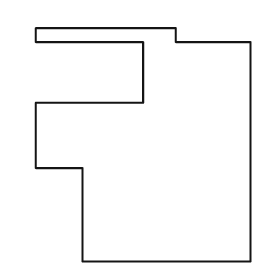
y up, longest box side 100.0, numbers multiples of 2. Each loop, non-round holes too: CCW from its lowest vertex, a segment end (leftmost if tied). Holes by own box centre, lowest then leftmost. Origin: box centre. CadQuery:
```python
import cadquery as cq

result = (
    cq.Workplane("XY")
    .moveTo(-26.0, -50.0)
    .lineTo(46.0, -50.0)
    .lineTo(46.0, 44.0)
    .lineTo(14.0, 44.0)
    .lineTo(14.0, 50.0)
    .lineTo(-46.0, 50.0)
    .lineTo(-46.0, 44.0)
    .lineTo(0.0, 44.0)
    .lineTo(0.0, 18.0)
    .lineTo(-46.0, 18.0)
    .lineTo(-46.0, -10.0)
    .lineTo(-26.0, -10.0)
    .close()
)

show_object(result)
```